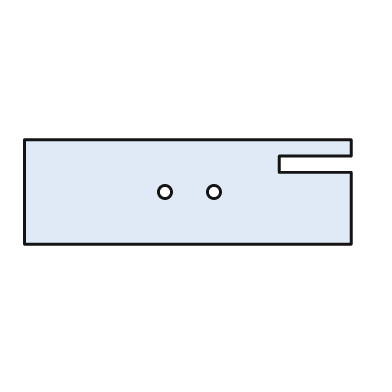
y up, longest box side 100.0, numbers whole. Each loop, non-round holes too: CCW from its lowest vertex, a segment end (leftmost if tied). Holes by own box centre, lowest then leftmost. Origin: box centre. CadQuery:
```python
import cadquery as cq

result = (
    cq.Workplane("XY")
    .moveTo(-50.0, -16.0)
    .lineTo(50.0, -16.0)
    .lineTo(50.0, 6.0)
    .lineTo(28.0, 6.0)
    .lineTo(28.0, 11.0)
    .lineTo(50.0, 11.0)
    .lineTo(50.0, 16.0)
    .lineTo(-50.0, 16.0)
    .close()
    .moveTo(-7.0, 0.0)
    .circle(2.0)
    .moveTo(8.0, 0.0)
    .circle(2.0)
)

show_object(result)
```